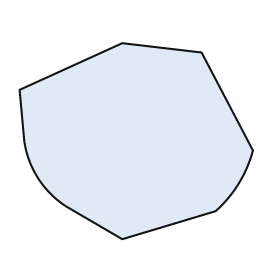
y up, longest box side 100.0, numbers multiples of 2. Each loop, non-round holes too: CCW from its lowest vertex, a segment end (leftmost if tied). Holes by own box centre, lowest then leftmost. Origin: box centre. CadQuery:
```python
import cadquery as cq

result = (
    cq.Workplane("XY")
    .moveTo(-6.0, -42.0)
    .lineTo(34.0, -30.0)
    .threePointArc((44.0, -18.0), (50.0, -4.0))
    .lineTo(28.0, 38.0)
    .lineTo(-6.0, 42.0)
    .lineTo(-50.0, 22.0)
    .lineTo(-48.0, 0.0)
    .threePointArc((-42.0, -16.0), (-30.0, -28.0))
    .close()
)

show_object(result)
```